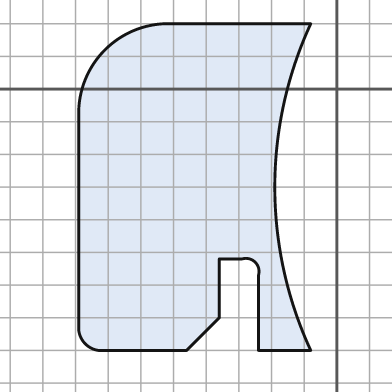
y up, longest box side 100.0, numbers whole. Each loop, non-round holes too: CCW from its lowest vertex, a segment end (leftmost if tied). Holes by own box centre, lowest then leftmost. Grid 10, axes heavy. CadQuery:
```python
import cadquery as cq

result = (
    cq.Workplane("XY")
    .moveTo(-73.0, -80.0)
    .lineTo(-46.0, -80.0)
    .lineTo(-36.0, -70.0)
    .lineTo(-36.0, -52.0)
    .lineTo(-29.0, -52.0)
    .threePointArc((-25.0, -53.0), (-24.0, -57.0))
    .lineTo(-24.0, -80.0)
    .lineTo(-8.0, -80.0)
    .threePointArc((-19.0, -30.0), (-8.0, 20.0))
    .lineTo(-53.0, 20.0)
    .threePointArc((-71.0, 12.0), (-79.0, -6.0))
    .lineTo(-79.0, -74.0)
    .threePointArc((-77.0, -78.0), (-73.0, -80.0))
    .close()
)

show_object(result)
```